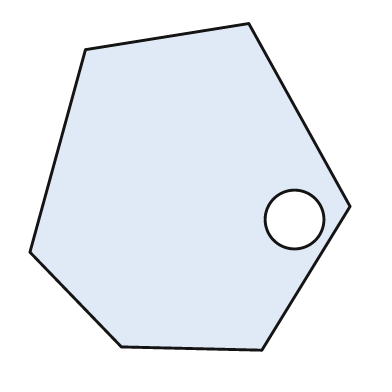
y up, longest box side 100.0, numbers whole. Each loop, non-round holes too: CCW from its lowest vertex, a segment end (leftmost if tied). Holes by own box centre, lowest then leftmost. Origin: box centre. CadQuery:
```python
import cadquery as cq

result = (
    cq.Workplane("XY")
    .moveTo(22.0, -50.0)
    .lineTo(49.0, -6.0)
    .lineTo(18.0, 50.0)
    .lineTo(-32.0, 42.0)
    .lineTo(-49.0, -20.0)
    .lineTo(-21.0, -49.0)
    .close()
    .moveTo(32.0, -10.0)
    .circle(9.0)
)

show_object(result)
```